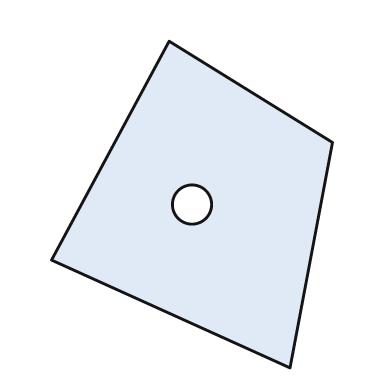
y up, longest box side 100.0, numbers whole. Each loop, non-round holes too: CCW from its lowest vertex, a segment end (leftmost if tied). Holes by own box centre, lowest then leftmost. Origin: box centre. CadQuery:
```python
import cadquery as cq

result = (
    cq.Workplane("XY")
    .moveTo(30.0, -50.0)
    .lineTo(43.0, 19.0)
    .lineTo(-7.0, 50.0)
    .lineTo(-43.0, -17.0)
    .close()
    .moveTo(0.0, 0.0)
    .circle(6.0)
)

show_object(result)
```